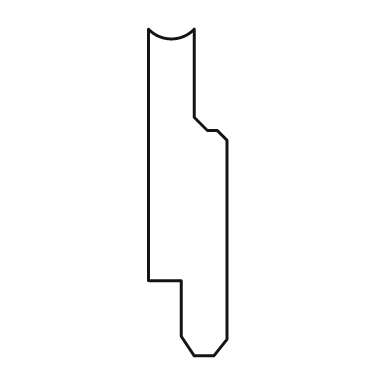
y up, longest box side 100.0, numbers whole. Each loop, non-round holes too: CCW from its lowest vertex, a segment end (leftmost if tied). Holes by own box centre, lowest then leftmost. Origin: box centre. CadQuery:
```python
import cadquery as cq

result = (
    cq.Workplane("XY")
    .moveTo(2.0, -50.0)
    .lineTo(8.0, -50.0)
    .lineTo(12.0, -45.0)
    .lineTo(12.0, 16.0)
    .lineTo(9.0, 19.0)
    .lineTo(6.0, 19.0)
    .lineTo(2.0, 23.0)
    .lineTo(2.0, 50.0)
    .threePointArc((-5.0, 47.0), (-12.0, 50.0))
    .lineTo(-12.0, -27.0)
    .lineTo(-2.0, -27.0)
    .lineTo(-2.0, -44.0)
    .close()
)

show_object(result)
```